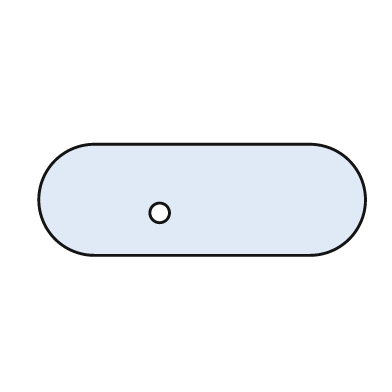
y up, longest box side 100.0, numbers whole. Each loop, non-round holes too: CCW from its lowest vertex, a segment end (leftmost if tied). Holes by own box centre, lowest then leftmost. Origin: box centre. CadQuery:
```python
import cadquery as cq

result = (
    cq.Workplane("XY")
    .moveTo(-33.0, -17.0)
    .lineTo(33.0, -17.0)
    .threePointArc((50.0, 0.0), (33.0, 17.0))
    .lineTo(-33.0, 17.0)
    .threePointArc((-50.0, 0.0), (-33.0, -17.0))
    .close()
    .moveTo(-13.0, -4.0)
    .circle(3.0)
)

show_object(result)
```